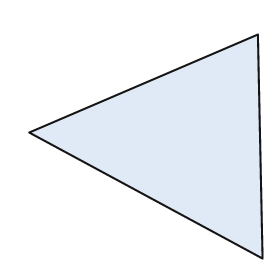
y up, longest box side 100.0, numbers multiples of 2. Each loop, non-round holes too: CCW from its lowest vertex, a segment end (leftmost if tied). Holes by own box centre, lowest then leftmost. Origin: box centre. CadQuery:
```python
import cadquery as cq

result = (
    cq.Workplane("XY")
    .moveTo(50.0, -48.0)
    .lineTo(48.0, 48.0)
    .lineTo(-50.0, 6.0)
    .close()
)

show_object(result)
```